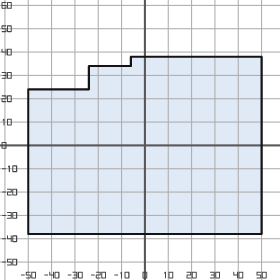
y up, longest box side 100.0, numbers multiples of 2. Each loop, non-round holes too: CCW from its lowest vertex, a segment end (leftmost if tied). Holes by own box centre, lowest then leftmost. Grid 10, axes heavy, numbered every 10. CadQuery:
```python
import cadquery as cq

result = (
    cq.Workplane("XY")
    .moveTo(-50.0, -38.0)
    .lineTo(50.0, -38.0)
    .lineTo(50.0, 38.0)
    .lineTo(-6.0, 38.0)
    .lineTo(-6.0, 34.0)
    .lineTo(-24.0, 34.0)
    .lineTo(-24.0, 24.0)
    .lineTo(-50.0, 24.0)
    .close()
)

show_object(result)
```